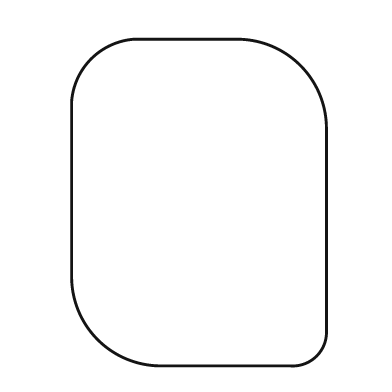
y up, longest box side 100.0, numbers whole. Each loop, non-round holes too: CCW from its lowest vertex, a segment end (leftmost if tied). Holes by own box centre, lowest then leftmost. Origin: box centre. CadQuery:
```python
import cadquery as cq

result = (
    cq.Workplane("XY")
    .moveTo(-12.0, -50.0)
    .lineTo(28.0, -50.0)
    .threePointArc((36.0, -47.0), (39.0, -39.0))
    .lineTo(39.0, 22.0)
    .threePointArc((31.0, 42.0), (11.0, 50.0))
    .lineTo(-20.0, 50.0)
    .threePointArc((-33.0, 44.0), (-39.0, 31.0))
    .lineTo(-39.0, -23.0)
    .threePointArc((-31.0, -42.0), (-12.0, -50.0))
    .close()
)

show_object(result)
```